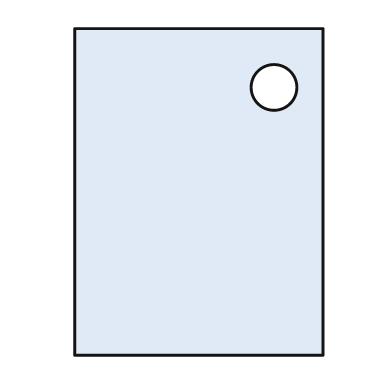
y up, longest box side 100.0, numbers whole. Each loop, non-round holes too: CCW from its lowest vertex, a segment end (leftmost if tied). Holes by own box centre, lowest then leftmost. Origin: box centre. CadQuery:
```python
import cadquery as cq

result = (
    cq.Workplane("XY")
    .moveTo(-38.0, -50.0)
    .lineTo(38.0, -50.0)
    .lineTo(38.0, 50.0)
    .lineTo(-38.0, 50.0)
    .close()
    .moveTo(23.0, 32.0)
    .circle(7.0)
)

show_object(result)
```